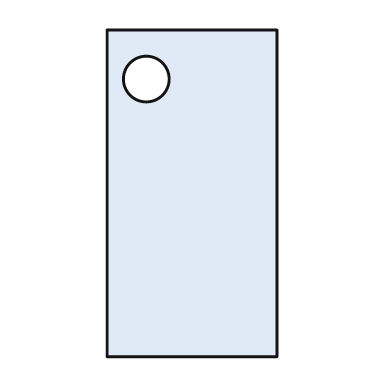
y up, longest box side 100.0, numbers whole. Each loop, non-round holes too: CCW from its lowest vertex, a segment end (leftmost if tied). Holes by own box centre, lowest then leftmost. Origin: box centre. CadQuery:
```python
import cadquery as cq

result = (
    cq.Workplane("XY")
    .moveTo(-26.0, -50.0)
    .lineTo(26.0, -50.0)
    .lineTo(26.0, 50.0)
    .lineTo(-26.0, 50.0)
    .close()
    .moveTo(-14.0, 35.0)
    .circle(7.0)
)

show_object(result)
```